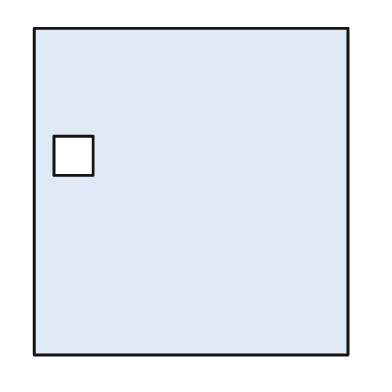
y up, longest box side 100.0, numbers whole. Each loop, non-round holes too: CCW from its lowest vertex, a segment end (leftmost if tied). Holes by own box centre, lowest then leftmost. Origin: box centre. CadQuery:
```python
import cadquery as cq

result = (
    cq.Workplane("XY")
    .moveTo(-48.0, -50.0)
    .lineTo(48.0, -50.0)
    .lineTo(48.0, 50.0)
    .lineTo(-48.0, 50.0)
    .close()
    .moveTo(-42.0, 5.0)
    .lineTo(-30.0, 5.0)
    .lineTo(-30.0, 17.0)
    .lineTo(-42.0, 17.0)
    .close()
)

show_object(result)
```